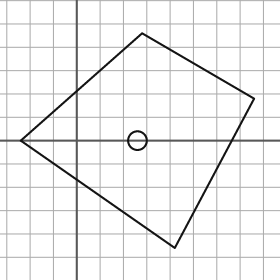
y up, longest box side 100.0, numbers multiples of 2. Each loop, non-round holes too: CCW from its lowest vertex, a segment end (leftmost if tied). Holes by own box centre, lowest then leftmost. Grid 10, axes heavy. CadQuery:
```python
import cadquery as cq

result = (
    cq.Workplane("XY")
    .moveTo(42.0, -46.0)
    .lineTo(76.0, 18.0)
    .lineTo(28.0, 46.0)
    .lineTo(-24.0, 0.0)
    .close()
    .moveTo(26.0, 0.0)
    .circle(4.0)
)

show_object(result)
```